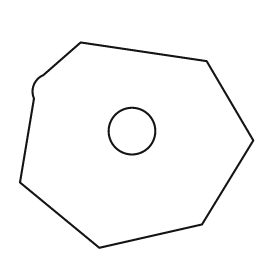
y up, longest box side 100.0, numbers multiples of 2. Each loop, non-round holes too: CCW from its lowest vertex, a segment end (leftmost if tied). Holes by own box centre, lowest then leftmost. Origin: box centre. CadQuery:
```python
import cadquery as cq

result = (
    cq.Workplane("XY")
    .moveTo(-16.0, -44.0)
    .lineTo(28.0, -34.0)
    .lineTo(50.0, 2.0)
    .lineTo(30.0, 36.0)
    .lineTo(-24.0, 44.0)
    .lineTo(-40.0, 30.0)
    .threePointArc((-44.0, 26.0), (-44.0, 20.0))
    .lineTo(-50.0, -16.0)
    .close()
    .moveTo(-2.0, 6.0)
    .circle(10.0)
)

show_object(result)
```